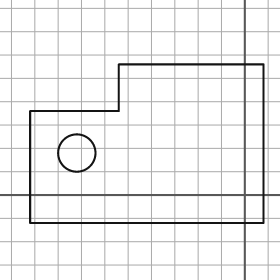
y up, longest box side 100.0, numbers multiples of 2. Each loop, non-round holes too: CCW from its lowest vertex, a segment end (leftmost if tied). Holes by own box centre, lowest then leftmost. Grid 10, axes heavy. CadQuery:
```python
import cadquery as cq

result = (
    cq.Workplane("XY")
    .moveTo(-92.0, -12.0)
    .lineTo(8.0, -12.0)
    .lineTo(8.0, 56.0)
    .lineTo(-54.0, 56.0)
    .lineTo(-54.0, 36.0)
    .lineTo(-92.0, 36.0)
    .close()
    .moveTo(-72.0, 18.0)
    .circle(8.0)
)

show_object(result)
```